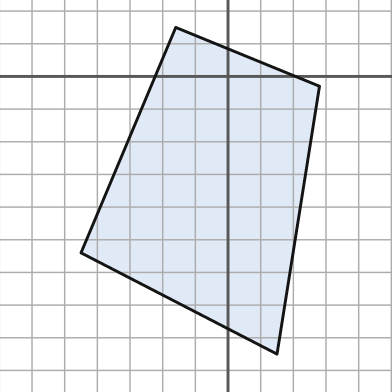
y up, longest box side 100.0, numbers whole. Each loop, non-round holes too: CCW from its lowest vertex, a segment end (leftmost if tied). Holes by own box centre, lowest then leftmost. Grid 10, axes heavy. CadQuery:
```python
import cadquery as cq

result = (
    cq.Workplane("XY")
    .moveTo(15.0, -85.0)
    .lineTo(28.0, -3.0)
    .lineTo(-16.0, 15.0)
    .lineTo(-45.0, -54.0)
    .close()
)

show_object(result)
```